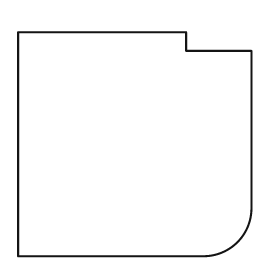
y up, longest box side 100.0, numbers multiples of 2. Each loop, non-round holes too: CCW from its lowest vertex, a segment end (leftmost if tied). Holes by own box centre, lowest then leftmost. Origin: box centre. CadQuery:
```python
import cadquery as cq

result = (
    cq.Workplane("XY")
    .moveTo(-50.0, -48.0)
    .lineTo(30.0, -48.0)
    .threePointArc((44.0, -42.0), (50.0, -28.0))
    .lineTo(50.0, 40.0)
    .lineTo(22.0, 40.0)
    .lineTo(22.0, 48.0)
    .lineTo(-50.0, 48.0)
    .close()
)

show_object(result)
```